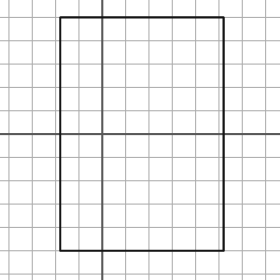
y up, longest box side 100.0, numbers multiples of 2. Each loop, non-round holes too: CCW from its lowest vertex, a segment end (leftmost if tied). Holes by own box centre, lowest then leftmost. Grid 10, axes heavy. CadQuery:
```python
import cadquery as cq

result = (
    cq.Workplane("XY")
    .moveTo(-18.0, -50.0)
    .lineTo(52.0, -50.0)
    .lineTo(52.0, 50.0)
    .lineTo(-18.0, 50.0)
    .close()
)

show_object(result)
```